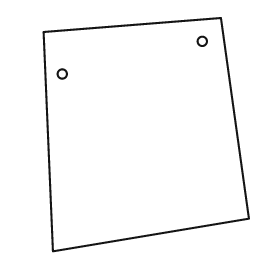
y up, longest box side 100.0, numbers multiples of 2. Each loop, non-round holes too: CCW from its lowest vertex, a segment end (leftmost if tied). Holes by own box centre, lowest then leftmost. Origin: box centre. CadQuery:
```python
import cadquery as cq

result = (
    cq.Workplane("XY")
    .moveTo(-40.0, -50.0)
    .lineTo(44.0, -36.0)
    .lineTo(32.0, 50.0)
    .lineTo(-44.0, 44.0)
    .close()
    .moveTo(-36.0, 26.0)
    .circle(2.0)
    .moveTo(24.0, 40.0)
    .circle(2.0)
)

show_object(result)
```